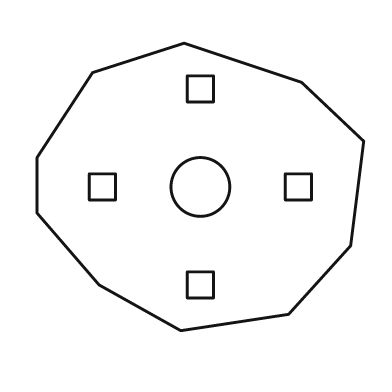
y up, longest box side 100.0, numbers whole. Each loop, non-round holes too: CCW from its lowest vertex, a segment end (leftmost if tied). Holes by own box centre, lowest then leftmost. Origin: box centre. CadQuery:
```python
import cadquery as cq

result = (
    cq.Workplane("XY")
    .moveTo(-6.0, -44.0)
    .lineTo(27.0, -39.0)
    .lineTo(46.0, -18.0)
    .lineTo(50.0, 14.0)
    .lineTo(31.0, 32.0)
    .lineTo(-5.0, 44.0)
    .lineTo(-33.0, 35.0)
    .lineTo(-50.0, 9.0)
    .lineTo(-50.0, -8.0)
    .lineTo(-31.0, -30.0)
    .close()
    .moveTo(-4.0, -34.0)
    .lineTo(4.0, -34.0)
    .lineTo(4.0, -26.0)
    .lineTo(-4.0, -26.0)
    .close()
    .moveTo(-34.0, -4.0)
    .lineTo(-26.0, -4.0)
    .lineTo(-26.0, 4.0)
    .lineTo(-34.0, 4.0)
    .close()
    .moveTo(0.0, 0.0)
    .circle(9.0)
    .moveTo(26.0, -4.0)
    .lineTo(34.0, -4.0)
    .lineTo(34.0, 4.0)
    .lineTo(26.0, 4.0)
    .close()
    .moveTo(-4.0, 26.0)
    .lineTo(4.0, 26.0)
    .lineTo(4.0, 34.0)
    .lineTo(-4.0, 34.0)
    .close()
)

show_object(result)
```